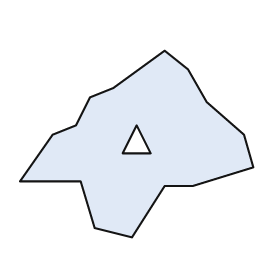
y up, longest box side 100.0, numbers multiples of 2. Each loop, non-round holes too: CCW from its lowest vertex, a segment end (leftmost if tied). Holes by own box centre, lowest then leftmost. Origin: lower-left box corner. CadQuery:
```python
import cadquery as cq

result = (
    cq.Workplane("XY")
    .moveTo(48.0, 0.0)
    .lineTo(62.0, 22.0)
    .lineTo(74.0, 22.0)
    .lineTo(100.0, 30.0)
    .lineTo(96.0, 44.0)
    .lineTo(80.0, 58.0)
    .lineTo(72.0, 72.0)
    .lineTo(62.0, 80.0)
    .lineTo(40.0, 64.0)
    .lineTo(30.0, 60.0)
    .lineTo(24.0, 48.0)
    .lineTo(14.0, 44.0)
    .lineTo(0.0, 24.0)
    .lineTo(26.0, 24.0)
    .lineTo(32.0, 4.0)
    .close()
    .moveTo(44.0, 36.0)
    .lineTo(56.0, 36.0)
    .lineTo(50.0, 48.0)
    .close()
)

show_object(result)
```